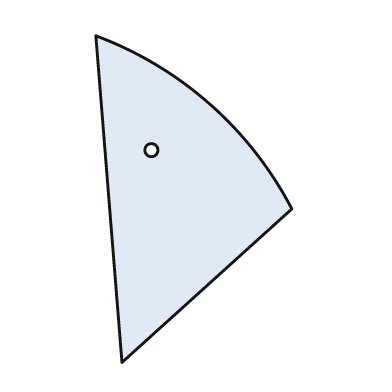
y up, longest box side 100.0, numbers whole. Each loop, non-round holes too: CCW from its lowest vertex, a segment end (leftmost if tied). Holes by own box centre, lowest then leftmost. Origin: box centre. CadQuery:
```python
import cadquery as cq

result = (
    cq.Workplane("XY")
    .moveTo(-22.0, -50.0)
    .lineTo(30.0, -3.0)
    .threePointArc((5.0, 29.0), (-30.0, 50.0))
    .close()
    .moveTo(-13.0, 15.0)
    .circle(2.0)
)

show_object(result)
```